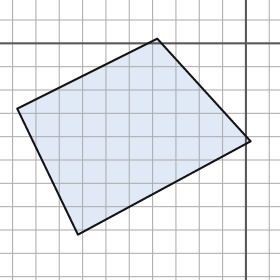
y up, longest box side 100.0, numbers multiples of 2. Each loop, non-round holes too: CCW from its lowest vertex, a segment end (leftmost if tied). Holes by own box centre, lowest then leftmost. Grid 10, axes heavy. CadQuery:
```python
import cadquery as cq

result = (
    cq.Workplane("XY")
    .moveTo(-72.0, -82.0)
    .lineTo(2.0, -42.0)
    .lineTo(-38.0, 2.0)
    .lineTo(-98.0, -28.0)
    .close()
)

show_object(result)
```